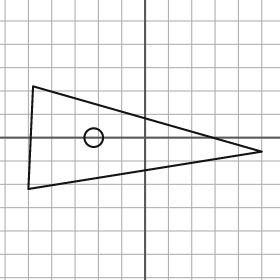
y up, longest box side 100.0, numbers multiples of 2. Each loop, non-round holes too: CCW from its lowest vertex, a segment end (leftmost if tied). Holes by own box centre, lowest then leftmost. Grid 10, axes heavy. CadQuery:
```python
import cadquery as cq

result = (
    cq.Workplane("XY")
    .moveTo(-50.0, -22.0)
    .lineTo(50.0, -6.0)
    .lineTo(-48.0, 22.0)
    .close()
    .moveTo(-22.0, 0.0)
    .circle(4.0)
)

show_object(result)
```